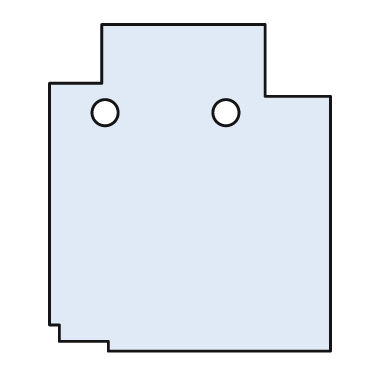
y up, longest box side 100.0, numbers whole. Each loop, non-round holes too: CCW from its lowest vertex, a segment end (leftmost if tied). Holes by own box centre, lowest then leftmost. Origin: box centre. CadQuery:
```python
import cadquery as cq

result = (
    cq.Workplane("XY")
    .moveTo(-25.0, -50.0)
    .lineTo(43.0, -50.0)
    .lineTo(43.0, 28.0)
    .lineTo(23.0, 28.0)
    .lineTo(23.0, 50.0)
    .lineTo(-27.0, 50.0)
    .lineTo(-27.0, 32.0)
    .lineTo(-43.0, 32.0)
    .lineTo(-43.0, -42.0)
    .lineTo(-40.0, -42.0)
    .lineTo(-40.0, -47.0)
    .lineTo(-25.0, -47.0)
    .close()
    .moveTo(-26.0, 23.0)
    .circle(4.0)
    .moveTo(11.0, 23.0)
    .circle(4.0)
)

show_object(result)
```